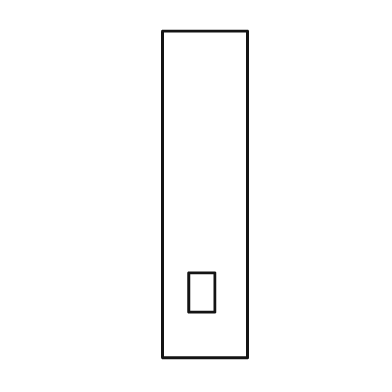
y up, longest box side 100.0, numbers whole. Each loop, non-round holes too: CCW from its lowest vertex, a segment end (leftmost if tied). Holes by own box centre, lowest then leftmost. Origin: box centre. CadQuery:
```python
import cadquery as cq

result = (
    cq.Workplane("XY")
    .moveTo(-13.0, -50.0)
    .lineTo(13.0, -50.0)
    .lineTo(13.0, 50.0)
    .lineTo(-13.0, 50.0)
    .close()
    .moveTo(-5.0, -36.0)
    .lineTo(3.0, -36.0)
    .lineTo(3.0, -24.0)
    .lineTo(-5.0, -24.0)
    .close()
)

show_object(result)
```